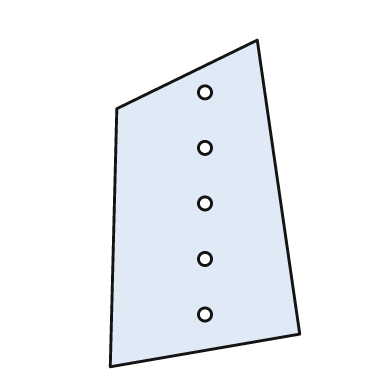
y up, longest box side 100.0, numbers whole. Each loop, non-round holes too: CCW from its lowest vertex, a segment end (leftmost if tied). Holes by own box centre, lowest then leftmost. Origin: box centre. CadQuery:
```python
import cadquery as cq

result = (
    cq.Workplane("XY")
    .moveTo(-29.0, -50.0)
    .lineTo(29.0, -40.0)
    .lineTo(16.0, 50.0)
    .lineTo(-27.0, 29.0)
    .close()
    .moveTo(0.0, -34.0)
    .circle(2.0)
    .moveTo(0.0, -17.0)
    .circle(2.0)
    .moveTo(0.0, 0.0)
    .circle(2.0)
    .moveTo(0.0, 17.0)
    .circle(2.0)
    .moveTo(0.0, 34.0)
    .circle(2.0)
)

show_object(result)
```